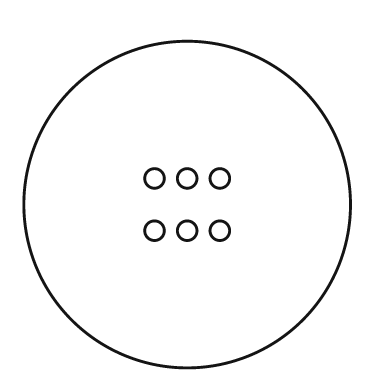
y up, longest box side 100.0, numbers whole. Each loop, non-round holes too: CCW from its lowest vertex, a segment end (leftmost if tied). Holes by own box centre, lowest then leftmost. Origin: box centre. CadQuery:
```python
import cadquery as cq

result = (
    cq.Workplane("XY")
    .moveTo(0.0, 0.0)
    .circle(50.0)
    .moveTo(-10.0, -8.0)
    .circle(3.0)
    .moveTo(0.0, -8.0)
    .circle(3.0)
    .moveTo(10.0, -8.0)
    .circle(3.0)
    .moveTo(-10.0, 8.0)
    .circle(3.0)
    .moveTo(0.0, 8.0)
    .circle(3.0)
    .moveTo(10.0, 8.0)
    .circle(3.0)
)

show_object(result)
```